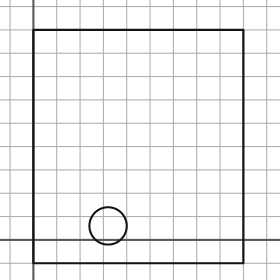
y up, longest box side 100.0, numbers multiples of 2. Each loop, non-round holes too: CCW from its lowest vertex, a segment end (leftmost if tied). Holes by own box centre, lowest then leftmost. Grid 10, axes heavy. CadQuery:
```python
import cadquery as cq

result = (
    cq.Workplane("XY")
    .moveTo(0.0, -10.0)
    .lineTo(90.0, -10.0)
    .lineTo(90.0, 90.0)
    .lineTo(0.0, 90.0)
    .close()
    .moveTo(32.0, 6.0)
    .circle(8.0)
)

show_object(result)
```